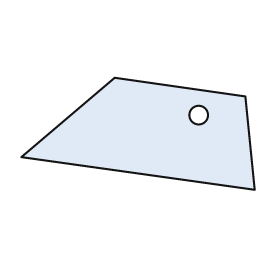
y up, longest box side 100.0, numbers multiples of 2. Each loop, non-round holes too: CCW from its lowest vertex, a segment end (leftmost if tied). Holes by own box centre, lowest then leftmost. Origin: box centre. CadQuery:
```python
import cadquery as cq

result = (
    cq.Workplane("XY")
    .moveTo(50.0, -24.0)
    .lineTo(46.0, 16.0)
    .lineTo(-10.0, 24.0)
    .lineTo(-50.0, -10.0)
    .close()
    .moveTo(26.0, 8.0)
    .circle(4.0)
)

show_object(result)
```